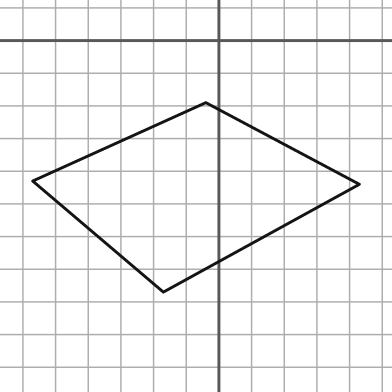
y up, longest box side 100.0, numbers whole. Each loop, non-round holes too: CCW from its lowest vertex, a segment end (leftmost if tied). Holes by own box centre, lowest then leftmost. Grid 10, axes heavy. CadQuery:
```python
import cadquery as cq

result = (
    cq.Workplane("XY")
    .moveTo(-17.0, -77.0)
    .lineTo(43.0, -44.0)
    .lineTo(-4.0, -19.0)
    .lineTo(-57.0, -43.0)
    .close()
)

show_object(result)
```